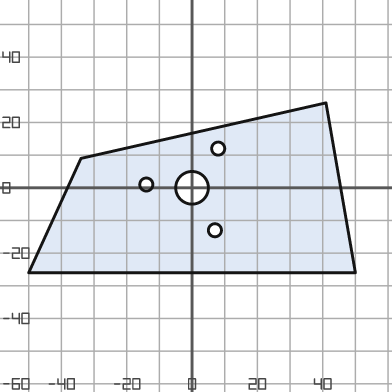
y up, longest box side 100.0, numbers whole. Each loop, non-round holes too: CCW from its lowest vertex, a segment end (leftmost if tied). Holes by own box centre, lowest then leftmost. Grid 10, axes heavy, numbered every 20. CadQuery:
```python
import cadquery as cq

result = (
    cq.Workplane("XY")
    .moveTo(-50.0, -26.0)
    .lineTo(50.0, -26.0)
    .lineTo(41.0, 26.0)
    .lineTo(-34.0, 9.0)
    .close()
    .moveTo(7.0, -13.0)
    .circle(2.0)
    .moveTo(0.0, 0.0)
    .circle(5.0)
    .moveTo(-14.0, 1.0)
    .circle(2.0)
    .moveTo(8.0, 12.0)
    .circle(2.0)
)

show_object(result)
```